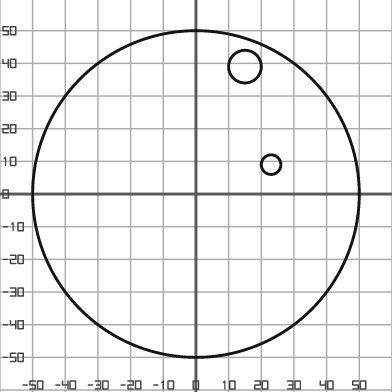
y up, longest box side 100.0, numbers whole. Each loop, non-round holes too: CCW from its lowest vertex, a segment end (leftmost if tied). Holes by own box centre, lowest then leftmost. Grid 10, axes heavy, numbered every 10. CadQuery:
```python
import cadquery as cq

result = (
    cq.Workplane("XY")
    .moveTo(0.0, 0.0)
    .circle(50.0)
    .moveTo(23.0, 9.0)
    .circle(3.0)
    .moveTo(15.0, 39.0)
    .circle(5.0)
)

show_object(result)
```